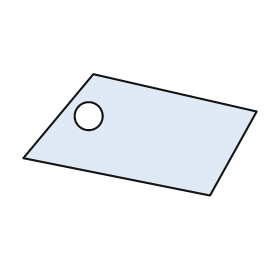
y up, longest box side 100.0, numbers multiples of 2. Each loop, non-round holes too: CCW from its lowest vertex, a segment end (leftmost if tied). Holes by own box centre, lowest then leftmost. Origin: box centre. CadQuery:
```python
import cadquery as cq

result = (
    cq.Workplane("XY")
    .moveTo(30.0, -26.0)
    .lineTo(50.0, 10.0)
    .lineTo(-20.0, 26.0)
    .lineTo(-50.0, -10.0)
    .close()
    .moveTo(-22.0, 8.0)
    .circle(6.0)
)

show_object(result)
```